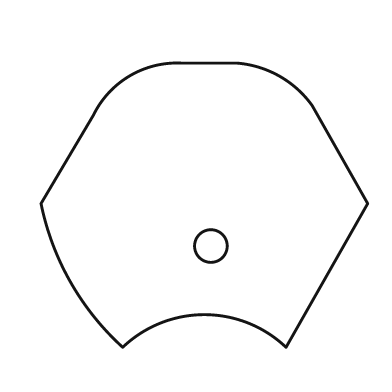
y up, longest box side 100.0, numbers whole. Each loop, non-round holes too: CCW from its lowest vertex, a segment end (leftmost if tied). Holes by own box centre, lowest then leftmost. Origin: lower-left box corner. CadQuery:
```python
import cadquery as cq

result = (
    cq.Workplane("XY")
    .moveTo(25.0, 0.0)
    .threePointArc((50.0, 10.0), (75.0, 0.0))
    .lineTo(100.0, 44.0)
    .lineTo(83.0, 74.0)
    .threePointArc((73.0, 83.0), (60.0, 87.0))
    .lineTo(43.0, 87.0)
    .threePointArc((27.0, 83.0), (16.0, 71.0))
    .lineTo(0.0, 44.0)
    .threePointArc((9.0, 20.0), (25.0, 0.0))
    .close()
    .moveTo(52.0, 31.0)
    .circle(5.0)
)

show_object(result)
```